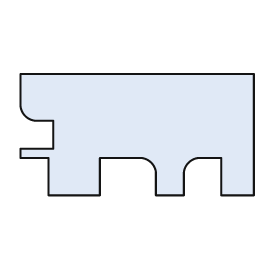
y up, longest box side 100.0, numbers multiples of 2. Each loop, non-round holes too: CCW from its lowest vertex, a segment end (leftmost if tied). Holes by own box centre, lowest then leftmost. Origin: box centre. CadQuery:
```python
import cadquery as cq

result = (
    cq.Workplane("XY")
    .moveTo(-38.0, -26.0)
    .lineTo(-16.0, -26.0)
    .lineTo(-16.0, -10.0)
    .lineTo(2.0, -10.0)
    .threePointArc((6.0, -12.0), (8.0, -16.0))
    .lineTo(8.0, -26.0)
    .lineTo(20.0, -26.0)
    .lineTo(20.0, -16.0)
    .threePointArc((22.0, -12.0), (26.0, -10.0))
    .lineTo(36.0, -10.0)
    .lineTo(36.0, -26.0)
    .lineTo(50.0, -26.0)
    .lineTo(50.0, 26.0)
    .lineTo(-50.0, 26.0)
    .lineTo(-50.0, 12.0)
    .threePointArc((-48.0, 8.0), (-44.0, 6.0))
    .lineTo(-36.0, 6.0)
    .lineTo(-36.0, -6.0)
    .lineTo(-50.0, -6.0)
    .lineTo(-50.0, -10.0)
    .lineTo(-38.0, -10.0)
    .close()
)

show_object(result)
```